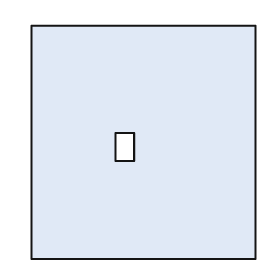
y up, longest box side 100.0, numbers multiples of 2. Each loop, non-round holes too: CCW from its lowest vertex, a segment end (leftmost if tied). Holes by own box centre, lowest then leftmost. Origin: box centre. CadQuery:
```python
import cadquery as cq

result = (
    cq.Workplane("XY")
    .moveTo(-48.0, -50.0)
    .lineTo(48.0, -50.0)
    .lineTo(48.0, 50.0)
    .lineTo(-48.0, 50.0)
    .close()
    .moveTo(-12.0, -8.0)
    .lineTo(-4.0, -8.0)
    .lineTo(-4.0, 4.0)
    .lineTo(-12.0, 4.0)
    .close()
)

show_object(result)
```